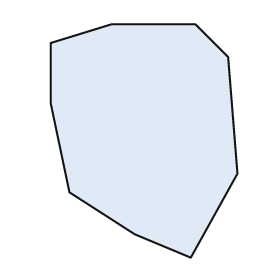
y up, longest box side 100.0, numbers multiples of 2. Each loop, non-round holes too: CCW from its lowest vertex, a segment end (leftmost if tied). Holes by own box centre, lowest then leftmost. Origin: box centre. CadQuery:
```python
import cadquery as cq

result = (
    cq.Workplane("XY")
    .moveTo(20.0, -50.0)
    .lineTo(40.0, -14.0)
    .lineTo(36.0, 36.0)
    .lineTo(22.0, 50.0)
    .lineTo(-14.0, 50.0)
    .lineTo(-40.0, 42.0)
    .lineTo(-40.0, 16.0)
    .lineTo(-32.0, -22.0)
    .lineTo(-4.0, -40.0)
    .close()
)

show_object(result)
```